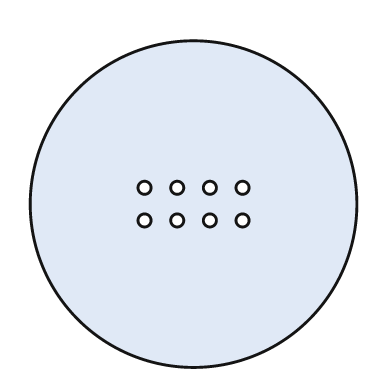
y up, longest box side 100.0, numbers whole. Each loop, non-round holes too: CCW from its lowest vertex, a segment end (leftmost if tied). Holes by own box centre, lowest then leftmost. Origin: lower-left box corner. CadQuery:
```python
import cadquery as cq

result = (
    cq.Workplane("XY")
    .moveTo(50.0, 50.0)
    .circle(50.0)
    .moveTo(35.0, 45.0)
    .circle(2.0)
    .moveTo(45.0, 45.0)
    .circle(2.0)
    .moveTo(55.0, 45.0)
    .circle(2.0)
    .moveTo(65.0, 45.0)
    .circle(2.0)
    .moveTo(35.0, 55.0)
    .circle(2.0)
    .moveTo(45.0, 55.0)
    .circle(2.0)
    .moveTo(55.0, 55.0)
    .circle(2.0)
    .moveTo(65.0, 55.0)
    .circle(2.0)
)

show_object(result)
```